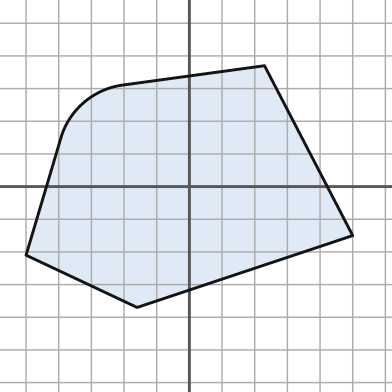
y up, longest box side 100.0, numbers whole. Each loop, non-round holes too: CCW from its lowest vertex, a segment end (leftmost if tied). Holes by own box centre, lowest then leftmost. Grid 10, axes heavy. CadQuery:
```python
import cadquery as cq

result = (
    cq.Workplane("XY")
    .moveTo(-16.0, -37.0)
    .lineTo(50.0, -15.0)
    .lineTo(23.0, 37.0)
    .lineTo(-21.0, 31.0)
    .threePointArc((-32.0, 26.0), (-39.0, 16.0))
    .lineTo(-50.0, -21.0)
    .close()
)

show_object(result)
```